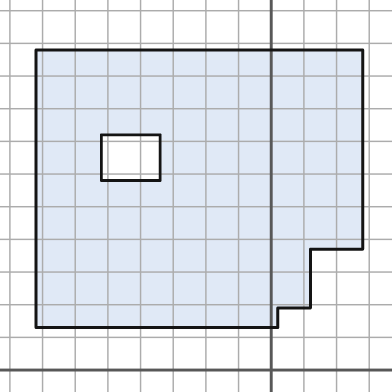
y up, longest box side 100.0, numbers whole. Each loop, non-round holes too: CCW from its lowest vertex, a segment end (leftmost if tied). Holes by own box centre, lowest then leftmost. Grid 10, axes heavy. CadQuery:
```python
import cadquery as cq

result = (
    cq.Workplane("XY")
    .moveTo(-72.0, 13.0)
    .lineTo(2.0, 13.0)
    .lineTo(2.0, 19.0)
    .lineTo(12.0, 19.0)
    .lineTo(12.0, 37.0)
    .lineTo(28.0, 37.0)
    .lineTo(28.0, 98.0)
    .lineTo(-72.0, 98.0)
    .close()
    .moveTo(-52.0, 58.0)
    .lineTo(-34.0, 58.0)
    .lineTo(-34.0, 72.0)
    .lineTo(-52.0, 72.0)
    .close()
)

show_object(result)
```